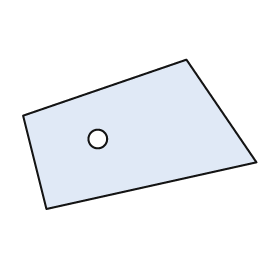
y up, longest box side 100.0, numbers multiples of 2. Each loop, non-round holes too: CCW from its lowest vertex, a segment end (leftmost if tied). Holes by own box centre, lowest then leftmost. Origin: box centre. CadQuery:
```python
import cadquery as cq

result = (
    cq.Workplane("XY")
    .moveTo(-40.0, -32.0)
    .lineTo(50.0, -12.0)
    .lineTo(20.0, 32.0)
    .lineTo(-50.0, 8.0)
    .close()
    .moveTo(-18.0, -2.0)
    .circle(4.0)
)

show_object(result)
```